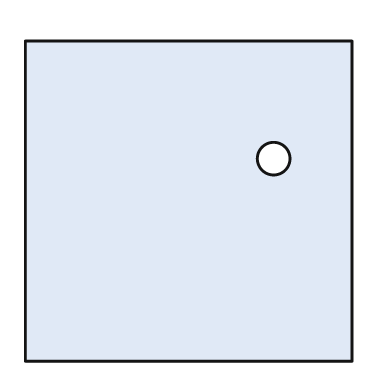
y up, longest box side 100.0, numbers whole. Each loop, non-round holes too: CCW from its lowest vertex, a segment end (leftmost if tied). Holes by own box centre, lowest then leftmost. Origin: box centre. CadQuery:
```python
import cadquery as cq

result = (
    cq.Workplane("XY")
    .moveTo(-50.0, -49.0)
    .lineTo(50.0, -49.0)
    .lineTo(50.0, 49.0)
    .lineTo(-50.0, 49.0)
    .close()
    .moveTo(26.0, 13.0)
    .circle(5.0)
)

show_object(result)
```